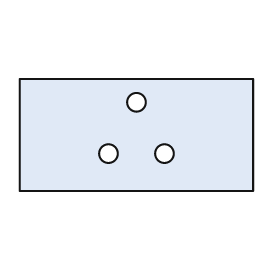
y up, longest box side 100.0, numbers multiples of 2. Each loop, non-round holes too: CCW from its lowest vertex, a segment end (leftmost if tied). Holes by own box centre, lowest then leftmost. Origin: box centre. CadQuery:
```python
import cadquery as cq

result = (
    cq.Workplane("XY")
    .moveTo(-50.0, -24.0)
    .lineTo(50.0, -24.0)
    .lineTo(50.0, 24.0)
    .lineTo(-50.0, 24.0)
    .close()
    .moveTo(-12.0, -8.0)
    .circle(4.0)
    .moveTo(12.0, -8.0)
    .circle(4.0)
    .moveTo(0.0, 14.0)
    .circle(4.0)
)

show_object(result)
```